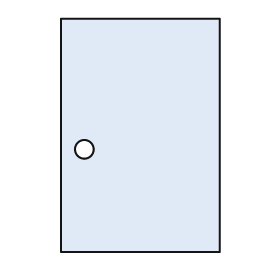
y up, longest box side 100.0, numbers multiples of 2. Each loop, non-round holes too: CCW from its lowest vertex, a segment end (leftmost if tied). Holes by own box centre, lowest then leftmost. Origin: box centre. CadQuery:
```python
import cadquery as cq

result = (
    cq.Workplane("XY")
    .moveTo(-34.0, -50.0)
    .lineTo(34.0, -50.0)
    .lineTo(34.0, 50.0)
    .lineTo(-34.0, 50.0)
    .close()
    .moveTo(-24.0, -6.0)
    .circle(4.0)
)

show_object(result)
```